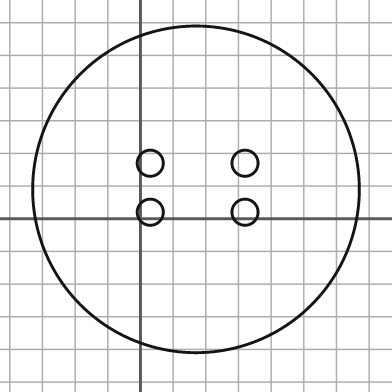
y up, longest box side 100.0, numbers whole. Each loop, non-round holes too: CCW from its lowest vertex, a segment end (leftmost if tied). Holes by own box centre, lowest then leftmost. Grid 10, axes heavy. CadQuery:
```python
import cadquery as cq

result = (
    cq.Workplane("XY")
    .moveTo(17.0, 9.0)
    .circle(50.0)
    .moveTo(3.0, 2.0)
    .circle(4.0)
    .moveTo(32.0, 2.0)
    .circle(4.0)
    .moveTo(3.0, 17.0)
    .circle(4.0)
    .moveTo(32.0, 17.0)
    .circle(4.0)
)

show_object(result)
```